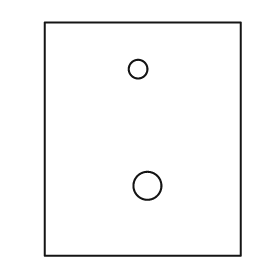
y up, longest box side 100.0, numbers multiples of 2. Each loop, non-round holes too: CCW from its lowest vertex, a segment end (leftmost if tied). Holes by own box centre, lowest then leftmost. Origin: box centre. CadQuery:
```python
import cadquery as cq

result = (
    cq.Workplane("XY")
    .moveTo(-42.0, -50.0)
    .lineTo(42.0, -50.0)
    .lineTo(42.0, 50.0)
    .lineTo(-42.0, 50.0)
    .close()
    .moveTo(2.0, -20.0)
    .circle(6.0)
    .moveTo(-2.0, 30.0)
    .circle(4.0)
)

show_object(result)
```